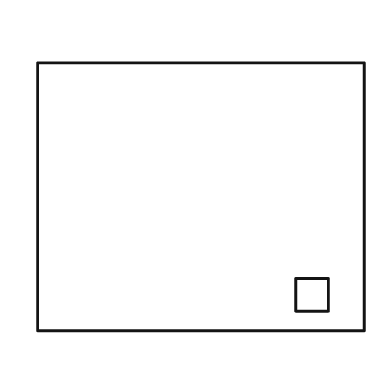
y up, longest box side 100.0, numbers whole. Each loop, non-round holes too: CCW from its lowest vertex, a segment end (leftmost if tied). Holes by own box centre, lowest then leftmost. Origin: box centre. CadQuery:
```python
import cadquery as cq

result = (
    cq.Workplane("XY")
    .moveTo(-50.0, -41.0)
    .lineTo(50.0, -41.0)
    .lineTo(50.0, 41.0)
    .lineTo(-50.0, 41.0)
    .close()
    .moveTo(29.0, -35.0)
    .lineTo(39.0, -35.0)
    .lineTo(39.0, -25.0)
    .lineTo(29.0, -25.0)
    .close()
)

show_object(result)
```